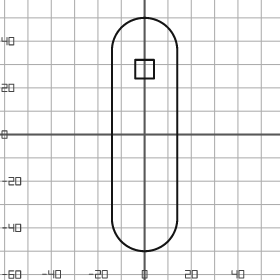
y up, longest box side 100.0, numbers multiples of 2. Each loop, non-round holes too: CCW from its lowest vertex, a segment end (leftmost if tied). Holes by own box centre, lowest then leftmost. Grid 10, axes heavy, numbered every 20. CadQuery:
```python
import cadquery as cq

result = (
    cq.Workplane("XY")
    .moveTo(-14.0, -36.0)
    .threePointArc((0.0, -50.0), (14.0, -36.0))
    .lineTo(14.0, 36.0)
    .threePointArc((0.0, 50.0), (-14.0, 36.0))
    .close()
    .moveTo(-4.0, 24.0)
    .lineTo(4.0, 24.0)
    .lineTo(4.0, 32.0)
    .lineTo(-4.0, 32.0)
    .close()
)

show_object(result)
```